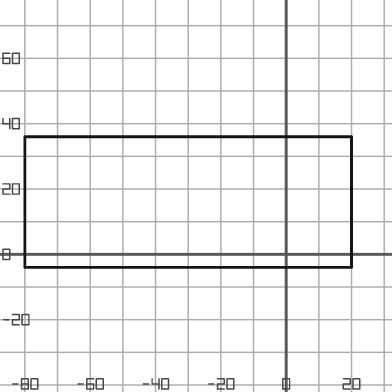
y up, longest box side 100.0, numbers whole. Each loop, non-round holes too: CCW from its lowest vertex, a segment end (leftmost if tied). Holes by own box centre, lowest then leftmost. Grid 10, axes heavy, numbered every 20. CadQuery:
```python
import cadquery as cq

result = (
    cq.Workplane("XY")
    .moveTo(-80.0, -4.0)
    .lineTo(20.0, -4.0)
    .lineTo(20.0, 36.0)
    .lineTo(-80.0, 36.0)
    .close()
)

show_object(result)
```